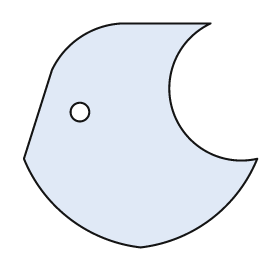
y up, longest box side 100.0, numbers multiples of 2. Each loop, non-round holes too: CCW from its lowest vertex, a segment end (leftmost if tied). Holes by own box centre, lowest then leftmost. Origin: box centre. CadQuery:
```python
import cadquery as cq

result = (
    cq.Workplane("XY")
    .moveTo(0.0, -48.0)
    .threePointArc((30.0, -36.0), (50.0, -10.0))
    .threePointArc((14.0, 10.0), (30.0, 48.0))
    .lineTo(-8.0, 48.0)
    .threePointArc((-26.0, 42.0), (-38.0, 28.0))
    .lineTo(-50.0, -10.0)
    .threePointArc((-30.0, -36.0), (0.0, -48.0))
    .close()
    .moveTo(-26.0, 10.0)
    .circle(4.0)
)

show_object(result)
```